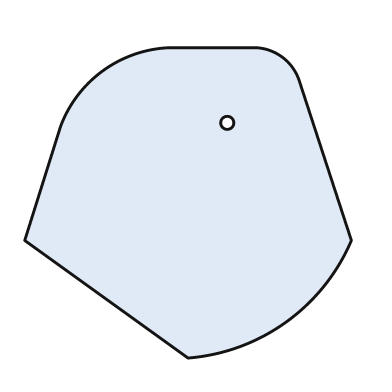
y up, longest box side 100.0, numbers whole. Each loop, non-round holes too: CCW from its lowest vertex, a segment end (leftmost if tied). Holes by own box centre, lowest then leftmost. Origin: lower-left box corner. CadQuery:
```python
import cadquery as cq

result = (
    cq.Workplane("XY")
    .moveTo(50.0, 0.0)
    .threePointArc((80.0, 11.0), (100.0, 36.0))
    .lineTo(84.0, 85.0)
    .threePointArc((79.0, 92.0), (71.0, 95.0))
    .lineTo(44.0, 95.0)
    .threePointArc((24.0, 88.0), (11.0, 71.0))
    .lineTo(0.0, 36.0)
    .close()
    .moveTo(62.0, 72.0)
    .circle(2.0)
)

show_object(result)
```